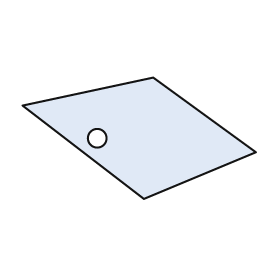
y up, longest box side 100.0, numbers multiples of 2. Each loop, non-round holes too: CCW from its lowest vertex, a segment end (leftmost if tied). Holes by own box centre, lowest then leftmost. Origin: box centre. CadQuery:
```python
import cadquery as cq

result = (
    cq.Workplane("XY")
    .moveTo(2.0, -26.0)
    .lineTo(50.0, -6.0)
    .lineTo(6.0, 26.0)
    .lineTo(-50.0, 14.0)
    .close()
    .moveTo(-18.0, 0.0)
    .circle(4.0)
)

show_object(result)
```